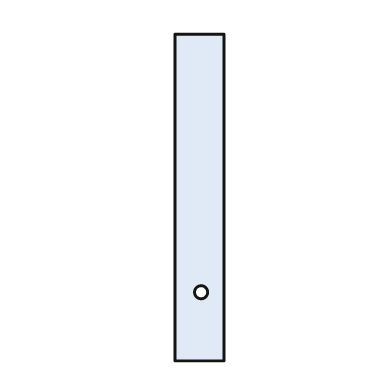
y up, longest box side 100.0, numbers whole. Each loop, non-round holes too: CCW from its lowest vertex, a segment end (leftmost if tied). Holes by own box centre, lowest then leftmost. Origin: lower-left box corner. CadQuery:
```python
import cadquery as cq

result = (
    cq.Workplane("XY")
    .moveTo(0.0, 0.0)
    .lineTo(15.0, 0.0)
    .lineTo(15.0, 100.0)
    .lineTo(0.0, 100.0)
    .close()
    .moveTo(8.0, 21.0)
    .circle(2.0)
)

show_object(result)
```